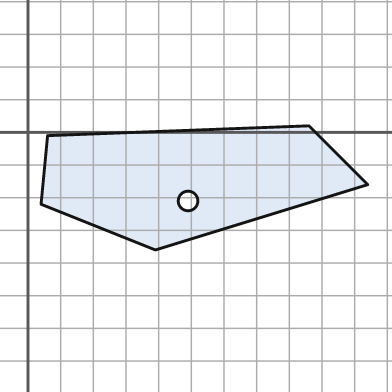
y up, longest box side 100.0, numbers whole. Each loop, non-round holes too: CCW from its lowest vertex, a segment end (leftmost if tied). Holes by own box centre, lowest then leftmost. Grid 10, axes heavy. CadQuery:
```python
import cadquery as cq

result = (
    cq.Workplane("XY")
    .moveTo(39.0, -36.0)
    .lineTo(104.0, -16.0)
    .lineTo(86.0, 2.0)
    .lineTo(6.0, -1.0)
    .lineTo(4.0, -22.0)
    .close()
    .moveTo(49.0, -21.0)
    .circle(3.0)
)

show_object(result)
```